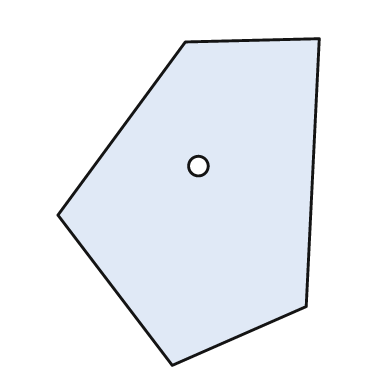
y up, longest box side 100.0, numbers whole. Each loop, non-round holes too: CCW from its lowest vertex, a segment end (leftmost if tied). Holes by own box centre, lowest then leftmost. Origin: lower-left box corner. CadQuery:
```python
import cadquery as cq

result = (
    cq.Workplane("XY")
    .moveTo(35.0, 0.0)
    .lineTo(76.0, 18.0)
    .lineTo(80.0, 100.0)
    .lineTo(39.0, 99.0)
    .lineTo(0.0, 46.0)
    .close()
    .moveTo(43.0, 61.0)
    .circle(3.0)
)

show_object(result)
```